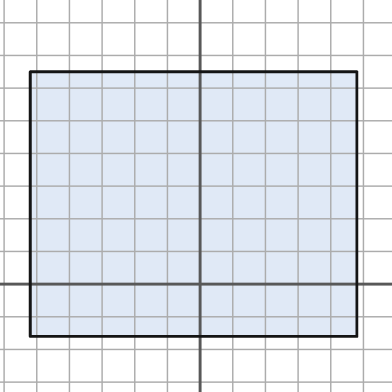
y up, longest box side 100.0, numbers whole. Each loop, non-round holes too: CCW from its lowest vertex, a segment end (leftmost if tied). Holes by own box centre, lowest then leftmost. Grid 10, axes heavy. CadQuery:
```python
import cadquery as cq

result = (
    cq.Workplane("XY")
    .moveTo(-52.0, -16.0)
    .lineTo(48.0, -16.0)
    .lineTo(48.0, 65.0)
    .lineTo(-52.0, 65.0)
    .close()
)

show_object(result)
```